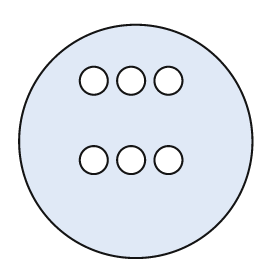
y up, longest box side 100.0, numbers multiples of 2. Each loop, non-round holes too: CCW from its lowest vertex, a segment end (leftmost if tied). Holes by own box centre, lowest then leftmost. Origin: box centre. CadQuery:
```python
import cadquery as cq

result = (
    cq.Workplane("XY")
    .moveTo(0.0, 0.0)
    .circle(50.0)
    .moveTo(-18.0, -8.0)
    .circle(6.0)
    .moveTo(-2.0, -8.0)
    .circle(6.0)
    .moveTo(14.0, -8.0)
    .circle(6.0)
    .moveTo(-18.0, 26.0)
    .circle(6.0)
    .moveTo(-2.0, 26.0)
    .circle(6.0)
    .moveTo(14.0, 26.0)
    .circle(6.0)
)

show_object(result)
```